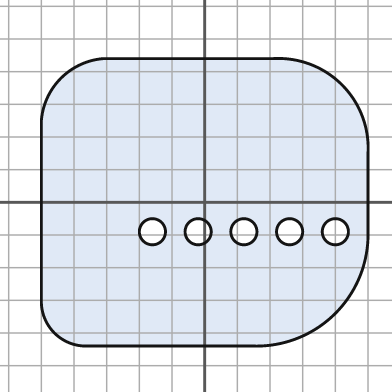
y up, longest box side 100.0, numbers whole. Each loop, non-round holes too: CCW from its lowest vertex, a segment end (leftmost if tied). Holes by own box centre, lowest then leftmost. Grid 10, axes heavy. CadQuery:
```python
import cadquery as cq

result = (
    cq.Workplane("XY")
    .moveTo(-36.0, -44.0)
    .lineTo(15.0, -44.0)
    .threePointArc((40.0, -34.0), (50.0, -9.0))
    .lineTo(50.0, 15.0)
    .threePointArc((42.0, 36.0), (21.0, 44.0))
    .lineTo(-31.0, 44.0)
    .threePointArc((-44.0, 38.0), (-50.0, 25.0))
    .lineTo(-50.0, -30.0)
    .threePointArc((-46.0, -40.0), (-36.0, -44.0))
    .close()
    .moveTo(-16.0, -9.0)
    .circle(4.0)
    .moveTo(-2.0, -9.0)
    .circle(4.0)
    .moveTo(12.0, -9.0)
    .circle(4.0)
    .moveTo(26.0, -9.0)
    .circle(4.0)
    .moveTo(40.0, -9.0)
    .circle(4.0)
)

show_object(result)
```